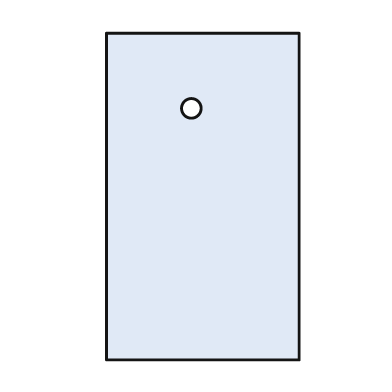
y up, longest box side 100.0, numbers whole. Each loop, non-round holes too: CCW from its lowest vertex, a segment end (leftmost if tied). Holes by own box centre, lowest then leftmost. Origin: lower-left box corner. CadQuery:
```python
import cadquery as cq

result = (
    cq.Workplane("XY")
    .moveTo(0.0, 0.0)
    .lineTo(59.0, 0.0)
    .lineTo(59.0, 100.0)
    .lineTo(0.0, 100.0)
    .close()
    .moveTo(26.0, 77.0)
    .circle(3.0)
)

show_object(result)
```